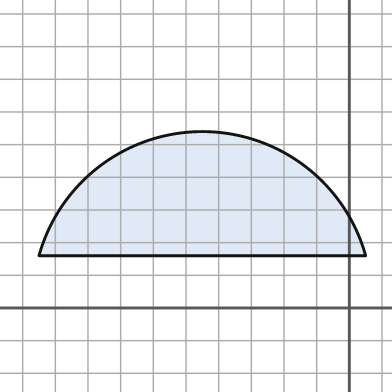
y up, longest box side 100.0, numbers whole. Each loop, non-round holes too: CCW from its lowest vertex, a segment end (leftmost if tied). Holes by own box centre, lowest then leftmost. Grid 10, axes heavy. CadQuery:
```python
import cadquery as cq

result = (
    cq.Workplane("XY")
    .moveTo(-95.0, 16.0)
    .lineTo(5.0, 16.0)
    .threePointArc((-45.0, 54.0), (-95.0, 16.0))
    .close()
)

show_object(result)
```